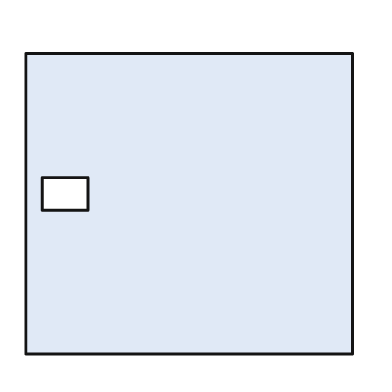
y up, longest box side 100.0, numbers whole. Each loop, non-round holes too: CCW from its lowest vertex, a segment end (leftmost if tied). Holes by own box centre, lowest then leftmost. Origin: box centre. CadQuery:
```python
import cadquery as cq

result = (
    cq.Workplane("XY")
    .moveTo(-50.0, -46.0)
    .lineTo(50.0, -46.0)
    .lineTo(50.0, 46.0)
    .lineTo(-50.0, 46.0)
    .close()
    .moveTo(-45.0, -2.0)
    .lineTo(-31.0, -2.0)
    .lineTo(-31.0, 8.0)
    .lineTo(-45.0, 8.0)
    .close()
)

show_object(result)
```